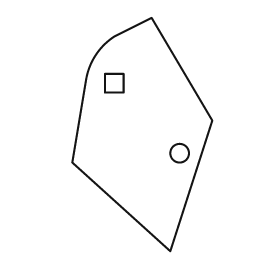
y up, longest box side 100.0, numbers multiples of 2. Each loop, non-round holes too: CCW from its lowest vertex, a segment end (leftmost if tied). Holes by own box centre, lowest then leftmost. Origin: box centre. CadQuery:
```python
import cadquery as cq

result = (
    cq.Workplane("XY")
    .moveTo(12.0, -50.0)
    .lineTo(30.0, 6.0)
    .lineTo(4.0, 50.0)
    .lineTo(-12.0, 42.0)
    .threePointArc((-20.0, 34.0), (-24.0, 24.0))
    .lineTo(-30.0, -12.0)
    .close()
    .moveTo(16.0, -8.0)
    .circle(4.0)
    .moveTo(-16.0, 18.0)
    .lineTo(-8.0, 18.0)
    .lineTo(-8.0, 26.0)
    .lineTo(-16.0, 26.0)
    .close()
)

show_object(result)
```